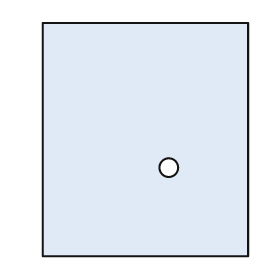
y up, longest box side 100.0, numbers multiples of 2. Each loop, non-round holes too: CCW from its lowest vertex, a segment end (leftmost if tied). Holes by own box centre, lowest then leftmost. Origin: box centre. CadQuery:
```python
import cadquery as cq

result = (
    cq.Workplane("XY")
    .moveTo(-44.0, -50.0)
    .lineTo(44.0, -50.0)
    .lineTo(44.0, 50.0)
    .lineTo(-44.0, 50.0)
    .close()
    .moveTo(10.0, -12.0)
    .circle(4.0)
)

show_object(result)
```